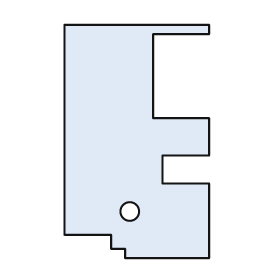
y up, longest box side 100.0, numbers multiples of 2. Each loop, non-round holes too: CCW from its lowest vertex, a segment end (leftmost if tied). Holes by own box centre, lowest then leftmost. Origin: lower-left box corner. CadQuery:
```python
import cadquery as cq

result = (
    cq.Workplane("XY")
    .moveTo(26.0, 0.0)
    .lineTo(62.0, 0.0)
    .lineTo(62.0, 32.0)
    .lineTo(42.0, 32.0)
    .lineTo(42.0, 44.0)
    .lineTo(62.0, 44.0)
    .lineTo(62.0, 60.0)
    .lineTo(38.0, 60.0)
    .lineTo(38.0, 96.0)
    .lineTo(62.0, 96.0)
    .lineTo(62.0, 100.0)
    .lineTo(0.0, 100.0)
    .lineTo(0.0, 10.0)
    .lineTo(20.0, 10.0)
    .lineTo(20.0, 4.0)
    .lineTo(26.0, 4.0)
    .close()
    .moveTo(28.0, 20.0)
    .circle(4.0)
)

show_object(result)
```